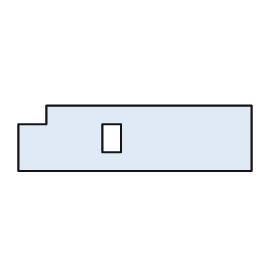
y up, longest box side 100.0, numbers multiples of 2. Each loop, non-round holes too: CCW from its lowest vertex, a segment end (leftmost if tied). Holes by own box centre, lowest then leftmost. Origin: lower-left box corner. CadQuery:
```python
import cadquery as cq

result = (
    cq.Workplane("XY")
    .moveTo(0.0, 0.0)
    .lineTo(100.0, 0.0)
    .lineTo(100.0, 28.0)
    .lineTo(12.0, 28.0)
    .lineTo(12.0, 20.0)
    .lineTo(0.0, 20.0)
    .close()
    .moveTo(36.0, 8.0)
    .lineTo(44.0, 8.0)
    .lineTo(44.0, 20.0)
    .lineTo(36.0, 20.0)
    .close()
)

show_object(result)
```